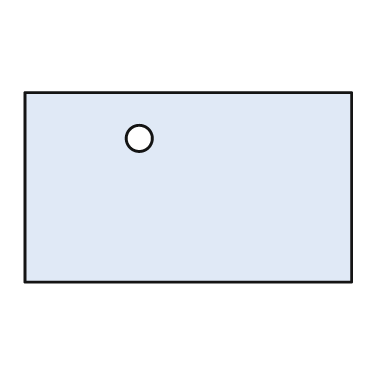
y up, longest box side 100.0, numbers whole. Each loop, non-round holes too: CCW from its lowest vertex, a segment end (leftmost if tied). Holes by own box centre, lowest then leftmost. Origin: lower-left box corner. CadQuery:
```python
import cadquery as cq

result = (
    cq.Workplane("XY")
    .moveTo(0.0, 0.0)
    .lineTo(100.0, 0.0)
    .lineTo(100.0, 58.0)
    .lineTo(0.0, 58.0)
    .close()
    .moveTo(35.0, 44.0)
    .circle(4.0)
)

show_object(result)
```